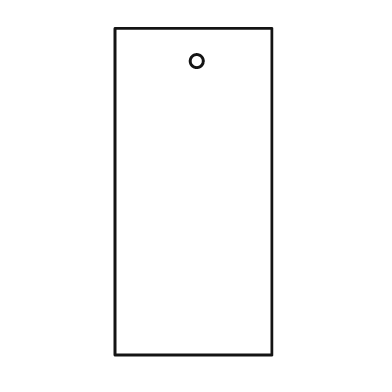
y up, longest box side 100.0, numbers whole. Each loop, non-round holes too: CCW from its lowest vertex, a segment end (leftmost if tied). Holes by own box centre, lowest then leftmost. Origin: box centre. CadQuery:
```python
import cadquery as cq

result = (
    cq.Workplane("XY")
    .moveTo(-24.0, -50.0)
    .lineTo(24.0, -50.0)
    .lineTo(24.0, 50.0)
    .lineTo(-24.0, 50.0)
    .close()
    .moveTo(1.0, 40.0)
    .circle(2.0)
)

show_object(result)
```